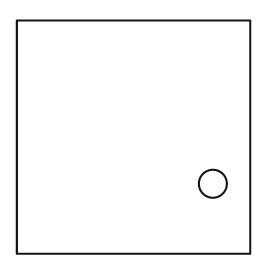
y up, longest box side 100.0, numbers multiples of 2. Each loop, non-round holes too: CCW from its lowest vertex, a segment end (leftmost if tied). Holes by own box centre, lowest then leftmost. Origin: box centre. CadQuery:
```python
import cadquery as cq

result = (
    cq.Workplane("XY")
    .moveTo(-50.0, -50.0)
    .lineTo(50.0, -50.0)
    .lineTo(50.0, 50.0)
    .lineTo(-50.0, 50.0)
    .close()
    .moveTo(34.0, -20.0)
    .circle(6.0)
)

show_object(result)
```